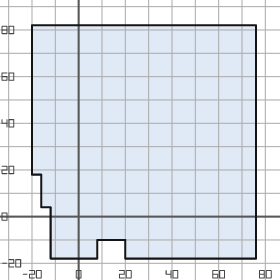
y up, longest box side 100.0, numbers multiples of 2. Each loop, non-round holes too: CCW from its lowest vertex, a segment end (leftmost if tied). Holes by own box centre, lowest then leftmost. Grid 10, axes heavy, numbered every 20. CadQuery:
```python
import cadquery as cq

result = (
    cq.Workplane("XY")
    .moveTo(-12.0, -18.0)
    .lineTo(8.0, -18.0)
    .lineTo(8.0, -10.0)
    .lineTo(20.0, -10.0)
    .lineTo(20.0, -18.0)
    .lineTo(76.0, -18.0)
    .lineTo(76.0, 82.0)
    .lineTo(-20.0, 82.0)
    .lineTo(-20.0, 18.0)
    .lineTo(-16.0, 18.0)
    .lineTo(-16.0, 4.0)
    .lineTo(-12.0, 4.0)
    .close()
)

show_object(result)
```